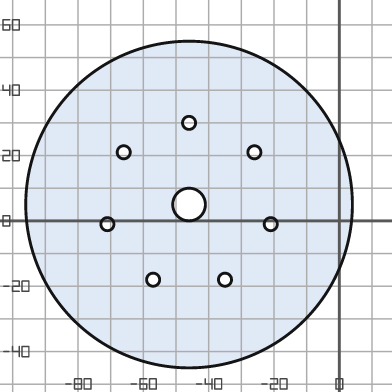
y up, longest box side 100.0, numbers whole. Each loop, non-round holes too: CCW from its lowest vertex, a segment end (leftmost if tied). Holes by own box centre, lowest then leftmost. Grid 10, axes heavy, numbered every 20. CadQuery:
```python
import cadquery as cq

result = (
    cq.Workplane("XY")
    .moveTo(-46.0, 5.0)
    .circle(50.0)
    .moveTo(-57.0, -18.0)
    .circle(2.0)
    .moveTo(-35.0, -18.0)
    .circle(2.0)
    .moveTo(-71.0, -1.0)
    .circle(2.0)
    .moveTo(-21.0, -1.0)
    .circle(2.0)
    .moveTo(-46.0, 5.0)
    .circle(5.0)
    .moveTo(-66.0, 21.0)
    .circle(2.0)
    .moveTo(-26.0, 21.0)
    .circle(2.0)
    .moveTo(-46.0, 30.0)
    .circle(2.0)
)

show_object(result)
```